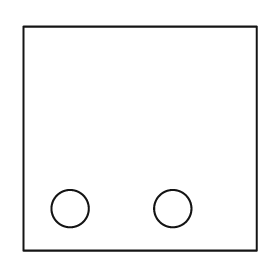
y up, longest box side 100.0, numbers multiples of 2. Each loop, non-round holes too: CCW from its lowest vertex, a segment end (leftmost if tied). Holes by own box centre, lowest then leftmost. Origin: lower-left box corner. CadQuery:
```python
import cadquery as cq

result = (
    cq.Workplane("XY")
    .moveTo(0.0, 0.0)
    .lineTo(100.0, 0.0)
    .lineTo(100.0, 96.0)
    .lineTo(0.0, 96.0)
    .close()
    .moveTo(20.0, 18.0)
    .circle(8.0)
    .moveTo(64.0, 18.0)
    .circle(8.0)
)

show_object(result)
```